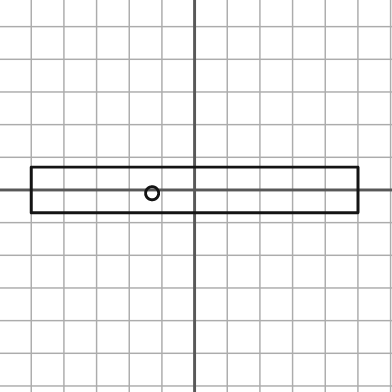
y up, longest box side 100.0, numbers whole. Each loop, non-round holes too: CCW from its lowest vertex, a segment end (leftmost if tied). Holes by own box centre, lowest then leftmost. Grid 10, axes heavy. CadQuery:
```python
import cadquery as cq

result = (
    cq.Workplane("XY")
    .moveTo(-50.0, -7.0)
    .lineTo(50.0, -7.0)
    .lineTo(50.0, 7.0)
    .lineTo(-50.0, 7.0)
    .close()
    .moveTo(-13.0, -1.0)
    .circle(2.0)
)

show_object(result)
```